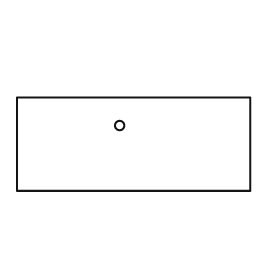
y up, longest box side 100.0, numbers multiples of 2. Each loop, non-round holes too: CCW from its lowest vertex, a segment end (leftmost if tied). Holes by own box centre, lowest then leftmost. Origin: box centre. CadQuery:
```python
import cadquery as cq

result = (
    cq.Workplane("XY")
    .moveTo(-50.0, -20.0)
    .lineTo(50.0, -20.0)
    .lineTo(50.0, 20.0)
    .lineTo(-50.0, 20.0)
    .close()
    .moveTo(-6.0, 8.0)
    .circle(2.0)
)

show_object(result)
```